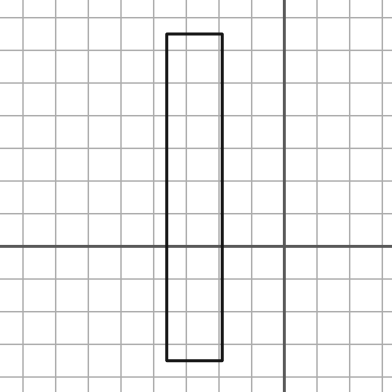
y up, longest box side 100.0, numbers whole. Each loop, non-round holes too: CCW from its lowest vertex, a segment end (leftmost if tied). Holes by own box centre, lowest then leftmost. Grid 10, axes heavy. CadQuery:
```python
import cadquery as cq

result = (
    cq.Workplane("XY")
    .moveTo(-36.0, -35.0)
    .lineTo(-19.0, -35.0)
    .lineTo(-19.0, 65.0)
    .lineTo(-36.0, 65.0)
    .close()
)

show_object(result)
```